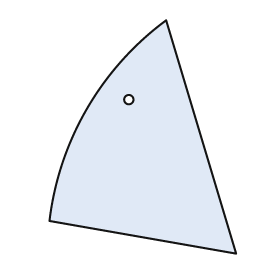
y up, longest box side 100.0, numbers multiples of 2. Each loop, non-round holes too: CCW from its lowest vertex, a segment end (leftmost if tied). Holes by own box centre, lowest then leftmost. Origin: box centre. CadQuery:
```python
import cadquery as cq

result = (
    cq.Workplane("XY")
    .moveTo(40.0, -50.0)
    .lineTo(10.0, 50.0)
    .threePointArc((-24.0, 12.0), (-40.0, -36.0))
    .close()
    .moveTo(-6.0, 16.0)
    .circle(2.0)
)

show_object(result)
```